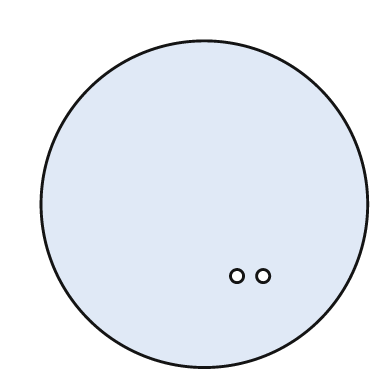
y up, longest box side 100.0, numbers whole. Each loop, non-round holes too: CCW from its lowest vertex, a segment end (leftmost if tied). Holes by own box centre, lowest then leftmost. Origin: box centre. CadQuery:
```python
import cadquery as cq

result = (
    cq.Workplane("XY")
    .moveTo(0.0, 0.0)
    .circle(50.0)
    .moveTo(10.0, -22.0)
    .circle(2.0)
    .moveTo(18.0, -22.0)
    .circle(2.0)
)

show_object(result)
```